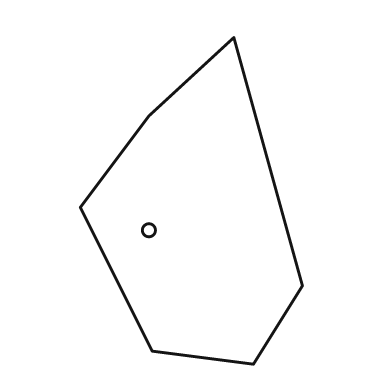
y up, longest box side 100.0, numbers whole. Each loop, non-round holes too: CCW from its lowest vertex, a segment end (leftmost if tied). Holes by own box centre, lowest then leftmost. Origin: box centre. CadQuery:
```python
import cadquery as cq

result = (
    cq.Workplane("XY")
    .moveTo(19.0, -50.0)
    .lineTo(34.0, -26.0)
    .lineTo(13.0, 50.0)
    .lineTo(-13.0, 26.0)
    .lineTo(-34.0, -2.0)
    .lineTo(-12.0, -46.0)
    .close()
    .moveTo(-13.0, -9.0)
    .circle(2.0)
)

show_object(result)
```